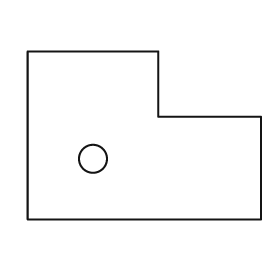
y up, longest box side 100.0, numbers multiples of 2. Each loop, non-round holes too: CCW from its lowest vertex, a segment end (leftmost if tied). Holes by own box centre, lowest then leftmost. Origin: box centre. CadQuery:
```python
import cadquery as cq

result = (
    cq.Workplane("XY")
    .moveTo(-50.0, -36.0)
    .lineTo(50.0, -36.0)
    .lineTo(50.0, 8.0)
    .lineTo(6.0, 8.0)
    .lineTo(6.0, 36.0)
    .lineTo(-50.0, 36.0)
    .close()
    .moveTo(-22.0, -10.0)
    .circle(6.0)
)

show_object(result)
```